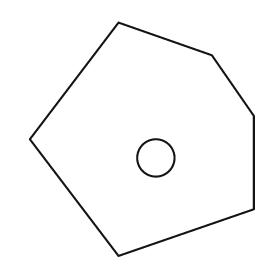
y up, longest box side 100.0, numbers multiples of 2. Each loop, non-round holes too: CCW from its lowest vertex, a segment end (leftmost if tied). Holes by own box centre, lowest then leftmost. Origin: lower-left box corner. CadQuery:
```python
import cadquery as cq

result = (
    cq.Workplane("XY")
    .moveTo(38.0, 0.0)
    .lineTo(96.0, 20.0)
    .lineTo(96.0, 60.0)
    .lineTo(78.0, 86.0)
    .lineTo(38.0, 100.0)
    .lineTo(0.0, 50.0)
    .close()
    .moveTo(54.0, 42.0)
    .circle(8.0)
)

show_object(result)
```